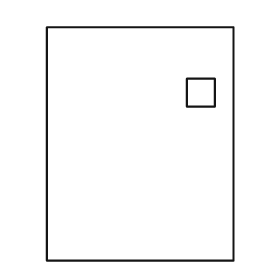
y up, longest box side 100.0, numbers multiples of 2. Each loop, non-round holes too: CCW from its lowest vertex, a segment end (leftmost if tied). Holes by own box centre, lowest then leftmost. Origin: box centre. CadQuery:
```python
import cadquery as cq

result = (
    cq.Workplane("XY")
    .moveTo(-40.0, -50.0)
    .lineTo(40.0, -50.0)
    .lineTo(40.0, 50.0)
    .lineTo(-40.0, 50.0)
    .close()
    .moveTo(20.0, 16.0)
    .lineTo(32.0, 16.0)
    .lineTo(32.0, 28.0)
    .lineTo(20.0, 28.0)
    .close()
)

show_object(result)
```